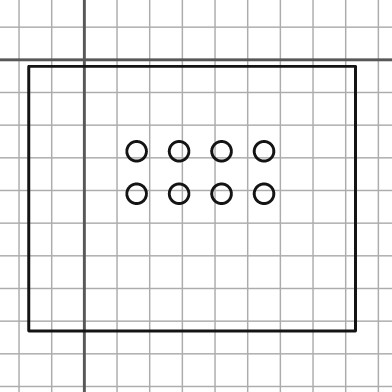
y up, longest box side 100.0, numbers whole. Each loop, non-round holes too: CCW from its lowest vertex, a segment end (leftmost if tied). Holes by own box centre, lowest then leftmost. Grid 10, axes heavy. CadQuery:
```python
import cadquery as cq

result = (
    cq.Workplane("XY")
    .moveTo(-17.0, -83.0)
    .lineTo(83.0, -83.0)
    .lineTo(83.0, -2.0)
    .lineTo(-17.0, -2.0)
    .close()
    .moveTo(16.0, -41.0)
    .circle(3.0)
    .moveTo(29.0, -41.0)
    .circle(3.0)
    .moveTo(42.0, -41.0)
    .circle(3.0)
    .moveTo(55.0, -41.0)
    .circle(3.0)
    .moveTo(16.0, -28.0)
    .circle(3.0)
    .moveTo(29.0, -28.0)
    .circle(3.0)
    .moveTo(42.0, -28.0)
    .circle(3.0)
    .moveTo(55.0, -28.0)
    .circle(3.0)
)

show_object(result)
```